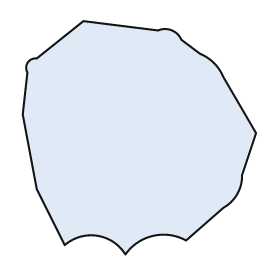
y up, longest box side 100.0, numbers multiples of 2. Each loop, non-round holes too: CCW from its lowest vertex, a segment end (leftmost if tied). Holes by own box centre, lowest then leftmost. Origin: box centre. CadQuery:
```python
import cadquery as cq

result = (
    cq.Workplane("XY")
    .moveTo(-6.0, -50.0)
    .threePointArc((6.0, -42.0), (20.0, -44.0))
    .lineTo(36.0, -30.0)
    .threePointArc((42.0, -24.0), (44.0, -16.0))
    .lineTo(50.0, 2.0)
    .lineTo(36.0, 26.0)
    .threePointArc((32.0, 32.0), (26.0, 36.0))
    .lineTo(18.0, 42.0)
    .threePointArc((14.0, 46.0), (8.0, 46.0))
    .lineTo(-24.0, 50.0)
    .lineTo(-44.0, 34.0)
    .threePointArc((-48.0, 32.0), (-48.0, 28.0))
    .lineTo(-50.0, 10.0)
    .lineTo(-44.0, -22.0)
    .lineTo(-32.0, -46.0)
    .threePointArc((-18.0, -42.0), (-6.0, -50.0))
    .close()
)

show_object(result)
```